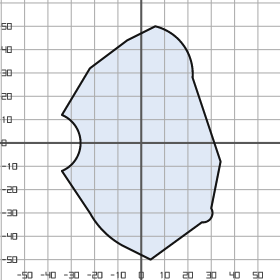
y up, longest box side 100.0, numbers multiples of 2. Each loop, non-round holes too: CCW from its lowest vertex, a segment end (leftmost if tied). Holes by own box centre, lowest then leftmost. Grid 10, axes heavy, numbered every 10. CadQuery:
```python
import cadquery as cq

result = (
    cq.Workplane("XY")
    .moveTo(4.0, -50.0)
    .lineTo(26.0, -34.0)
    .threePointArc((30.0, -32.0), (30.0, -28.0))
    .lineTo(34.0, -8.0)
    .lineTo(22.0, 28.0)
    .threePointArc((18.0, 42.0), (6.0, 50.0))
    .lineTo(-6.0, 44.0)
    .lineTo(-22.0, 32.0)
    .lineTo(-34.0, 12.0)
    .threePointArc((-26.0, 0.0), (-34.0, -12.0))
    .lineTo(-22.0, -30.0)
    .threePointArc((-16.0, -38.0), (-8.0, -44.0))
    .close()
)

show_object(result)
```